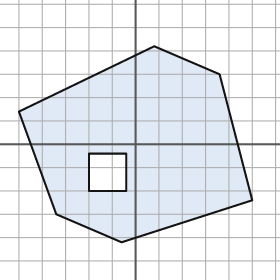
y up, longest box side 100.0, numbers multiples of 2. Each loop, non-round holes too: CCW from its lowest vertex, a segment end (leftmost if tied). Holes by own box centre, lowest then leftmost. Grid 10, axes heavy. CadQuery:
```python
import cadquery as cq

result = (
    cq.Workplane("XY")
    .moveTo(-6.0, -42.0)
    .lineTo(50.0, -24.0)
    .lineTo(36.0, 30.0)
    .lineTo(8.0, 42.0)
    .lineTo(-50.0, 14.0)
    .lineTo(-34.0, -30.0)
    .close()
    .moveTo(-20.0, -20.0)
    .lineTo(-4.0, -20.0)
    .lineTo(-4.0, -4.0)
    .lineTo(-20.0, -4.0)
    .close()
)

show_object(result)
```